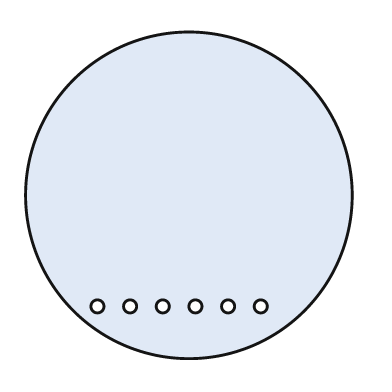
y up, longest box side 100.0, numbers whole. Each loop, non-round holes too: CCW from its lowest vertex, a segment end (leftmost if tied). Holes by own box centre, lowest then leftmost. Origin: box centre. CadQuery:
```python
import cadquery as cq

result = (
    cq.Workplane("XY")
    .moveTo(0.0, 0.0)
    .circle(50.0)
    .moveTo(-28.0, -34.0)
    .circle(2.0)
    .moveTo(-18.0, -34.0)
    .circle(2.0)
    .moveTo(-8.0, -34.0)
    .circle(2.0)
    .moveTo(2.0, -34.0)
    .circle(2.0)
    .moveTo(12.0, -34.0)
    .circle(2.0)
    .moveTo(22.0, -34.0)
    .circle(2.0)
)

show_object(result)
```